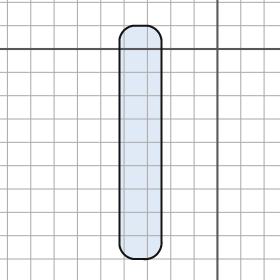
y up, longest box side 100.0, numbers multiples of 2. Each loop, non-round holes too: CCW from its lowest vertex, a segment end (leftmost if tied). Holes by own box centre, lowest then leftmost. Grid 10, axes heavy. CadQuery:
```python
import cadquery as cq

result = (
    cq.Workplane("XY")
    .moveTo(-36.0, -90.0)
    .lineTo(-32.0, -90.0)
    .threePointArc((-26.0, -88.0), (-24.0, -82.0))
    .lineTo(-24.0, 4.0)
    .threePointArc((-26.0, 8.0), (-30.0, 10.0))
    .lineTo(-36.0, 10.0)
    .threePointArc((-40.0, 8.0), (-42.0, 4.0))
    .lineTo(-42.0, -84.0)
    .threePointArc((-40.0, -88.0), (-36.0, -90.0))
    .close()
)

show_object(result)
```